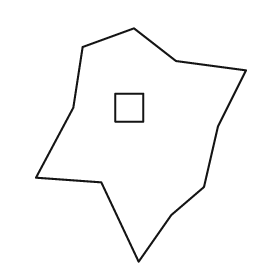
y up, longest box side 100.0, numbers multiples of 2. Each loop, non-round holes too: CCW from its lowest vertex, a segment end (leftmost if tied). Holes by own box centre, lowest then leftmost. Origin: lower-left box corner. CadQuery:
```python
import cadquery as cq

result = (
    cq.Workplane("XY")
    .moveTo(44.0, 0.0)
    .lineTo(58.0, 20.0)
    .lineTo(72.0, 32.0)
    .lineTo(78.0, 58.0)
    .lineTo(90.0, 82.0)
    .lineTo(60.0, 86.0)
    .lineTo(42.0, 100.0)
    .lineTo(20.0, 92.0)
    .lineTo(16.0, 66.0)
    .lineTo(0.0, 36.0)
    .lineTo(28.0, 34.0)
    .close()
    .moveTo(34.0, 60.0)
    .lineTo(46.0, 60.0)
    .lineTo(46.0, 72.0)
    .lineTo(34.0, 72.0)
    .close()
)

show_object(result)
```